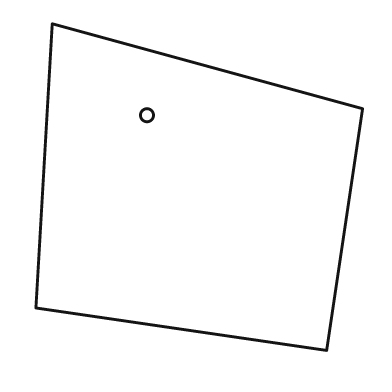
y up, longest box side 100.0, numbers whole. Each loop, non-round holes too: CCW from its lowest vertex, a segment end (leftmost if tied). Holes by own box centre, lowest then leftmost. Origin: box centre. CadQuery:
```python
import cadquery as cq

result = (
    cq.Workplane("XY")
    .moveTo(39.0, -50.0)
    .lineTo(50.0, 24.0)
    .lineTo(-45.0, 50.0)
    .lineTo(-50.0, -37.0)
    .close()
    .moveTo(-16.0, 22.0)
    .circle(2.0)
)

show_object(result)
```